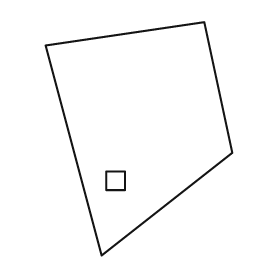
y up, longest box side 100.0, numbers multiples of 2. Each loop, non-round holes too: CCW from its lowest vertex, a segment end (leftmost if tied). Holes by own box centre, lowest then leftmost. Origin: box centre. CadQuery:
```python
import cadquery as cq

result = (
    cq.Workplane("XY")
    .moveTo(-16.0, -50.0)
    .lineTo(40.0, -6.0)
    .lineTo(28.0, 50.0)
    .lineTo(-40.0, 40.0)
    .close()
    .moveTo(-14.0, -22.0)
    .lineTo(-6.0, -22.0)
    .lineTo(-6.0, -14.0)
    .lineTo(-14.0, -14.0)
    .close()
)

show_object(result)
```